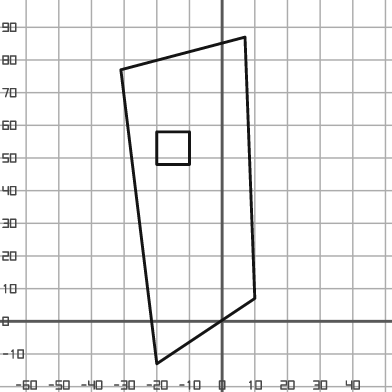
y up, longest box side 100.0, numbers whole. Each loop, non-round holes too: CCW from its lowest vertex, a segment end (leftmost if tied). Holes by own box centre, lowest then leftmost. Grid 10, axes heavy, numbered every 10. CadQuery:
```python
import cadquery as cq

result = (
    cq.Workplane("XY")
    .moveTo(-20.0, -13.0)
    .lineTo(10.0, 7.0)
    .lineTo(7.0, 87.0)
    .lineTo(-31.0, 77.0)
    .close()
    .moveTo(-20.0, 48.0)
    .lineTo(-10.0, 48.0)
    .lineTo(-10.0, 58.0)
    .lineTo(-20.0, 58.0)
    .close()
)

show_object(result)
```